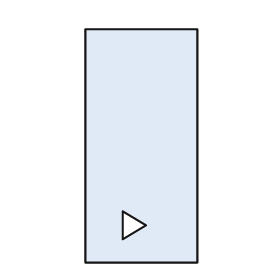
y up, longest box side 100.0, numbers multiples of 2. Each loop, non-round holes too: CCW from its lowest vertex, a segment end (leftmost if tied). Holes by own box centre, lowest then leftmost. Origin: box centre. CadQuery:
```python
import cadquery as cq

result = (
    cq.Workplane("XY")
    .moveTo(-24.0, -50.0)
    .lineTo(24.0, -50.0)
    .lineTo(24.0, 50.0)
    .lineTo(-24.0, 50.0)
    .close()
    .moveTo(-8.0, -40.0)
    .lineTo(2.0, -34.0)
    .lineTo(-8.0, -28.0)
    .close()
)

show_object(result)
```